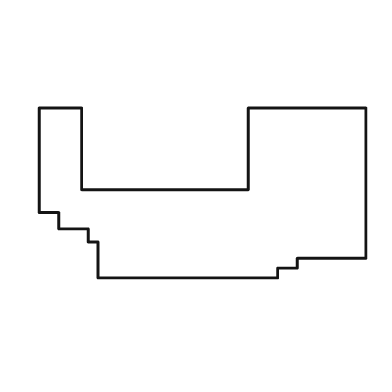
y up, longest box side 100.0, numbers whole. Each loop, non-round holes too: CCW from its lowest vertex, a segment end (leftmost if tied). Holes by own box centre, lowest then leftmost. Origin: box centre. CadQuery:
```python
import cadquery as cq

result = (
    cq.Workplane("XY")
    .moveTo(-32.0, -26.0)
    .lineTo(23.0, -26.0)
    .lineTo(23.0, -23.0)
    .lineTo(29.0, -23.0)
    .lineTo(29.0, -20.0)
    .lineTo(50.0, -20.0)
    .lineTo(50.0, 26.0)
    .lineTo(14.0, 26.0)
    .lineTo(14.0, 1.0)
    .lineTo(-37.0, 1.0)
    .lineTo(-37.0, 26.0)
    .lineTo(-50.0, 26.0)
    .lineTo(-50.0, -6.0)
    .lineTo(-44.0, -6.0)
    .lineTo(-44.0, -11.0)
    .lineTo(-35.0, -11.0)
    .lineTo(-35.0, -15.0)
    .lineTo(-32.0, -15.0)
    .close()
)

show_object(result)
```